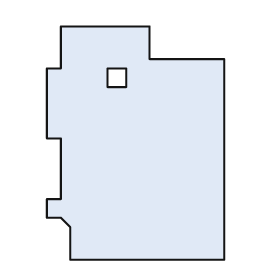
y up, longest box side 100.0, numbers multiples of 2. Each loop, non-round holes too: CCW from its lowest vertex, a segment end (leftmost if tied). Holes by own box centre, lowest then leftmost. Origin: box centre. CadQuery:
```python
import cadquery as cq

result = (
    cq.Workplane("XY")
    .moveTo(-28.0, -50.0)
    .lineTo(38.0, -50.0)
    .lineTo(38.0, 36.0)
    .lineTo(6.0, 36.0)
    .lineTo(6.0, 50.0)
    .lineTo(-32.0, 50.0)
    .lineTo(-32.0, 32.0)
    .lineTo(-38.0, 32.0)
    .lineTo(-38.0, 2.0)
    .lineTo(-32.0, 2.0)
    .lineTo(-32.0, -24.0)
    .lineTo(-38.0, -24.0)
    .lineTo(-38.0, -32.0)
    .lineTo(-32.0, -32.0)
    .lineTo(-28.0, -36.0)
    .close()
    .moveTo(-12.0, 24.0)
    .lineTo(-4.0, 24.0)
    .lineTo(-4.0, 32.0)
    .lineTo(-12.0, 32.0)
    .close()
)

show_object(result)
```